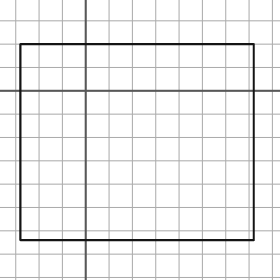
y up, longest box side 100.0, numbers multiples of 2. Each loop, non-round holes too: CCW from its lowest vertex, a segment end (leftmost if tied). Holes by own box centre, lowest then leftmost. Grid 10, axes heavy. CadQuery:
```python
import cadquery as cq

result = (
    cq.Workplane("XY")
    .moveTo(-28.0, -64.0)
    .lineTo(72.0, -64.0)
    .lineTo(72.0, 20.0)
    .lineTo(-28.0, 20.0)
    .close()
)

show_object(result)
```